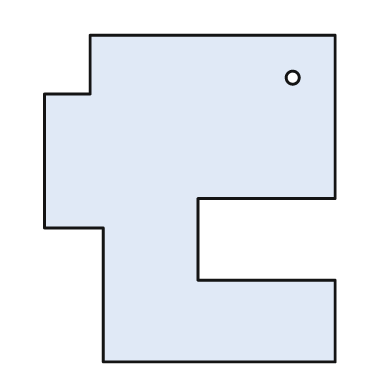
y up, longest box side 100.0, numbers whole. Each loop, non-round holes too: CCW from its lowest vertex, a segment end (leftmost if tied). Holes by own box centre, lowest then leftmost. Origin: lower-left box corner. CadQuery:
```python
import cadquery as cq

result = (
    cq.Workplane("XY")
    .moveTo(18.0, 0.0)
    .lineTo(89.0, 0.0)
    .lineTo(89.0, 25.0)
    .lineTo(47.0, 25.0)
    .lineTo(47.0, 50.0)
    .lineTo(89.0, 50.0)
    .lineTo(89.0, 100.0)
    .lineTo(14.0, 100.0)
    .lineTo(14.0, 82.0)
    .lineTo(0.0, 82.0)
    .lineTo(0.0, 41.0)
    .lineTo(18.0, 41.0)
    .close()
    .moveTo(76.0, 87.0)
    .circle(2.0)
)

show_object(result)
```